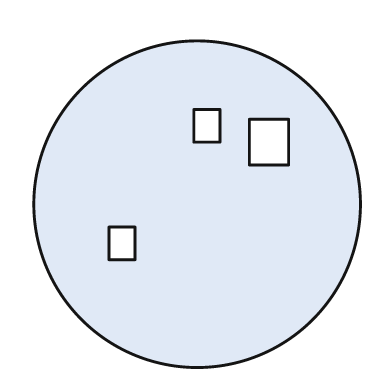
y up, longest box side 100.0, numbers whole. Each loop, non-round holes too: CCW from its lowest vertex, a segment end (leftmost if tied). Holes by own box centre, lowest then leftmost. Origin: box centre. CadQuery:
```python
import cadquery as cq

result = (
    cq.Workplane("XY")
    .moveTo(0.0, 0.0)
    .circle(50.0)
    .moveTo(-27.0, -17.0)
    .lineTo(-19.0, -17.0)
    .lineTo(-19.0, -7.0)
    .lineTo(-27.0, -7.0)
    .close()
    .moveTo(16.0, 12.0)
    .lineTo(28.0, 12.0)
    .lineTo(28.0, 26.0)
    .lineTo(16.0, 26.0)
    .close()
    .moveTo(-1.0, 19.0)
    .lineTo(7.0, 19.0)
    .lineTo(7.0, 29.0)
    .lineTo(-1.0, 29.0)
    .close()
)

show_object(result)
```